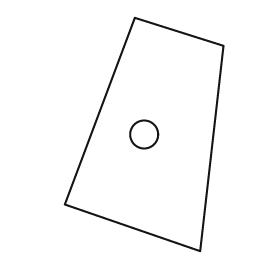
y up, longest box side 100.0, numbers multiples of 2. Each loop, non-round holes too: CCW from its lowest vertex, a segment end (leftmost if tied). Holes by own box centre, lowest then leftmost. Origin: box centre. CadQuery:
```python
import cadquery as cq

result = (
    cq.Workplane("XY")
    .moveTo(24.0, -50.0)
    .lineTo(34.0, 38.0)
    .lineTo(-4.0, 50.0)
    .lineTo(-34.0, -30.0)
    .close()
    .moveTo(0.0, 0.0)
    .circle(6.0)
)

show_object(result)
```